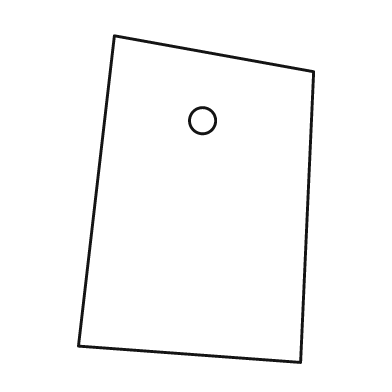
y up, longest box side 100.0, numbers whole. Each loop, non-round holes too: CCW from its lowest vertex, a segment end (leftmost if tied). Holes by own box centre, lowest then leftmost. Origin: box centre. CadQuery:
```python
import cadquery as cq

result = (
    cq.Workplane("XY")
    .moveTo(32.0, -50.0)
    .lineTo(36.0, 39.0)
    .lineTo(-25.0, 50.0)
    .lineTo(-36.0, -45.0)
    .close()
    .moveTo(2.0, 24.0)
    .circle(4.0)
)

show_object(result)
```